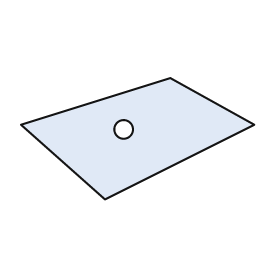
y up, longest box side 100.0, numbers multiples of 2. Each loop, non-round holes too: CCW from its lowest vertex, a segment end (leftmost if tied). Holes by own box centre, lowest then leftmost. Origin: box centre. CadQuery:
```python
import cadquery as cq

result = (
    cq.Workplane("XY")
    .moveTo(-14.0, -26.0)
    .lineTo(50.0, 6.0)
    .lineTo(14.0, 26.0)
    .lineTo(-50.0, 6.0)
    .close()
    .moveTo(-6.0, 4.0)
    .circle(4.0)
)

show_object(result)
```